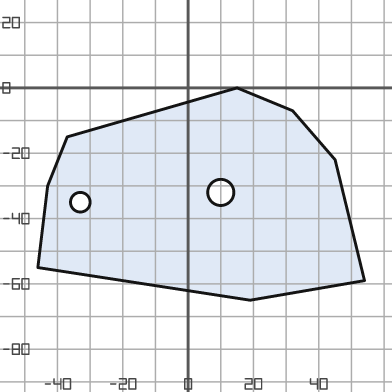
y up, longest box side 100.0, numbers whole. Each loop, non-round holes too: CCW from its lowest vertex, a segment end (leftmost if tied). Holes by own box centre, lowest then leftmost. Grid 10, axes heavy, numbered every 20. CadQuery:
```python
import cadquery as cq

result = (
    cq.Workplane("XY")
    .moveTo(19.0, -65.0)
    .lineTo(54.0, -59.0)
    .lineTo(45.0, -22.0)
    .lineTo(32.0, -7.0)
    .lineTo(15.0, 0.0)
    .lineTo(-37.0, -15.0)
    .lineTo(-43.0, -30.0)
    .lineTo(-46.0, -55.0)
    .close()
    .moveTo(-33.0, -35.0)
    .circle(3.0)
    .moveTo(10.0, -32.0)
    .circle(4.0)
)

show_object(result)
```